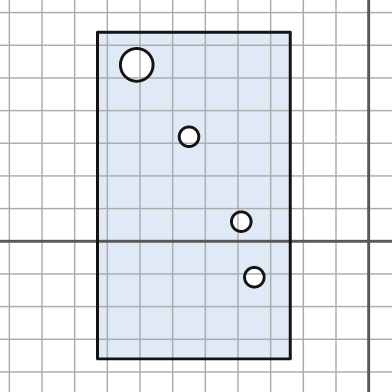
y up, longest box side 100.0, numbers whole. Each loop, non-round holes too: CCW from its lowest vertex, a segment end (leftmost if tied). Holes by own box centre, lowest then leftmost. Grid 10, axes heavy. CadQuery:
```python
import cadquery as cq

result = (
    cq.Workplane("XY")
    .moveTo(-83.0, -36.0)
    .lineTo(-24.0, -36.0)
    .lineTo(-24.0, 64.0)
    .lineTo(-83.0, 64.0)
    .close()
    .moveTo(-35.0, -11.0)
    .circle(3.0)
    .moveTo(-39.0, 6.0)
    .circle(3.0)
    .moveTo(-55.0, 32.0)
    .circle(3.0)
    .moveTo(-71.0, 54.0)
    .circle(5.0)
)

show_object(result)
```